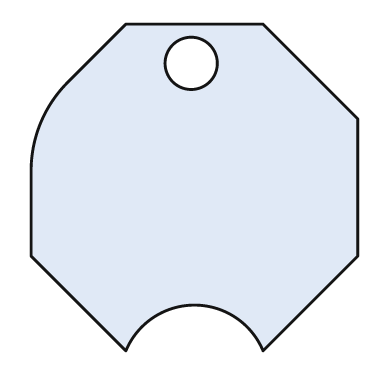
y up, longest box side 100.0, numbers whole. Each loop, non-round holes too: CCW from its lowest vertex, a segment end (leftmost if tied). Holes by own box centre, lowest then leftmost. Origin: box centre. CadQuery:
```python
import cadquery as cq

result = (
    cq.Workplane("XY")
    .moveTo(-21.0, -50.0)
    .threePointArc((0.0, -36.0), (21.0, -50.0))
    .lineTo(50.0, -21.0)
    .lineTo(50.0, 21.0)
    .lineTo(21.0, 50.0)
    .lineTo(-21.0, 50.0)
    .lineTo(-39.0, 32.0)
    .threePointArc((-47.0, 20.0), (-50.0, 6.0))
    .lineTo(-50.0, -21.0)
    .close()
    .moveTo(-1.0, 38.0)
    .circle(8.0)
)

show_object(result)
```